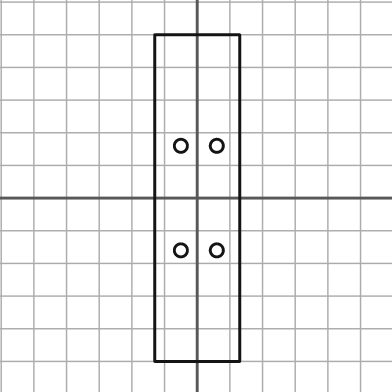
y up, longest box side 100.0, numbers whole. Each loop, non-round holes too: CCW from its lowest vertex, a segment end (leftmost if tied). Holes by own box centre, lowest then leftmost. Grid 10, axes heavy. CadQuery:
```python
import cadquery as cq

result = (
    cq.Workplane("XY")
    .moveTo(-13.0, -50.0)
    .lineTo(13.0, -50.0)
    .lineTo(13.0, 50.0)
    .lineTo(-13.0, 50.0)
    .close()
    .moveTo(-5.0, -16.0)
    .circle(2.0)
    .moveTo(6.0, -16.0)
    .circle(2.0)
    .moveTo(-5.0, 16.0)
    .circle(2.0)
    .moveTo(6.0, 16.0)
    .circle(2.0)
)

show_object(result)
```